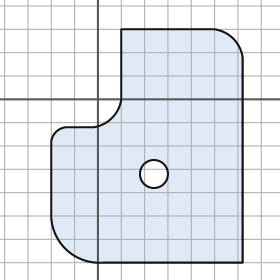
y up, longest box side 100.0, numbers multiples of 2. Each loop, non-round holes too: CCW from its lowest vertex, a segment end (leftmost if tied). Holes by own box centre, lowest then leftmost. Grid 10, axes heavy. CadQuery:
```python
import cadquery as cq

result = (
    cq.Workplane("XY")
    .moveTo(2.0, -70.0)
    .lineTo(62.0, -70.0)
    .lineTo(62.0, 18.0)
    .threePointArc((58.0, 26.0), (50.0, 30.0))
    .lineTo(10.0, 30.0)
    .lineTo(10.0, 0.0)
    .threePointArc((6.0, -8.0), (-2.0, -12.0))
    .lineTo(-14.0, -12.0)
    .threePointArc((-18.0, -14.0), (-20.0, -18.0))
    .lineTo(-20.0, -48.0)
    .threePointArc((-14.0, -64.0), (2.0, -70.0))
    .close()
    .moveTo(24.0, -32.0)
    .circle(6.0)
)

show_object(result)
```